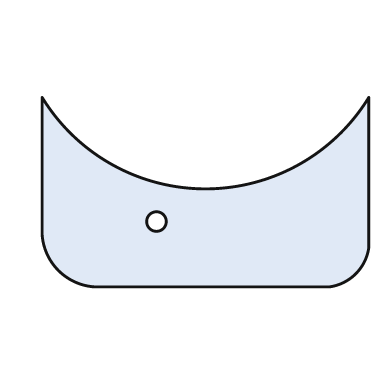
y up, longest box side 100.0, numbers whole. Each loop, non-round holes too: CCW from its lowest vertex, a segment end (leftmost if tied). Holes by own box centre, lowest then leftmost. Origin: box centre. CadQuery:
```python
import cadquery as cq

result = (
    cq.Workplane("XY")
    .moveTo(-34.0, -29.0)
    .lineTo(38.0, -29.0)
    .threePointArc((46.0, -25.0), (50.0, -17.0))
    .lineTo(50.0, 29.0)
    .threePointArc((0.0, 1.0), (-50.0, 29.0))
    .lineTo(-50.0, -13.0)
    .threePointArc((-45.0, -24.0), (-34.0, -29.0))
    .close()
    .moveTo(-15.0, -9.0)
    .circle(3.0)
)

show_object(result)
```